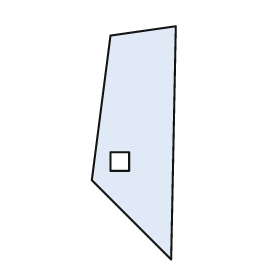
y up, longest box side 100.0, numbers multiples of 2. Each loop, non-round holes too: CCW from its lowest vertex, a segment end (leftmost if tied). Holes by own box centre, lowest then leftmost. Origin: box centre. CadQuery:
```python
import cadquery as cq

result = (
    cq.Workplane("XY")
    .moveTo(16.0, -50.0)
    .lineTo(18.0, 50.0)
    .lineTo(-10.0, 46.0)
    .lineTo(-18.0, -16.0)
    .close()
    .moveTo(-10.0, -12.0)
    .lineTo(-2.0, -12.0)
    .lineTo(-2.0, -4.0)
    .lineTo(-10.0, -4.0)
    .close()
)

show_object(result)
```